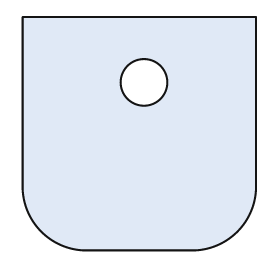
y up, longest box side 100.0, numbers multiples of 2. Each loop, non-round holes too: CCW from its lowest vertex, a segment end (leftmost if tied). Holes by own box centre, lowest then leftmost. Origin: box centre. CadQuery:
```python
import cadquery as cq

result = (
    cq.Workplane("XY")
    .moveTo(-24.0, -50.0)
    .lineTo(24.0, -50.0)
    .threePointArc((42.0, -42.0), (50.0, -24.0))
    .lineTo(50.0, 50.0)
    .lineTo(-50.0, 50.0)
    .lineTo(-50.0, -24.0)
    .threePointArc((-42.0, -42.0), (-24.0, -50.0))
    .close()
    .moveTo(2.0, 22.0)
    .circle(10.0)
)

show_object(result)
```